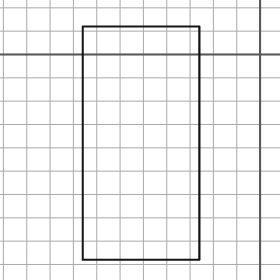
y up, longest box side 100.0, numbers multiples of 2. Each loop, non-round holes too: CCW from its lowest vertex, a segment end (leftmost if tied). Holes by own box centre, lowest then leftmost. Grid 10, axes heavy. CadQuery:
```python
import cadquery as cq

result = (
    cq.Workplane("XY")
    .moveTo(-76.0, -88.0)
    .lineTo(-26.0, -88.0)
    .lineTo(-26.0, 12.0)
    .lineTo(-76.0, 12.0)
    .close()
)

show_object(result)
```